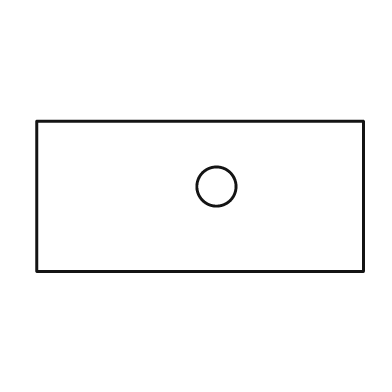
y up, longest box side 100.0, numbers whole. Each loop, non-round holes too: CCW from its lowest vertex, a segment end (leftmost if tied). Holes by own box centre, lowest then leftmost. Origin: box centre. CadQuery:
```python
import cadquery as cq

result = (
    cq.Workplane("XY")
    .moveTo(-50.0, -23.0)
    .lineTo(50.0, -23.0)
    .lineTo(50.0, 23.0)
    .lineTo(-50.0, 23.0)
    .close()
    .moveTo(5.0, 3.0)
    .circle(6.0)
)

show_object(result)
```